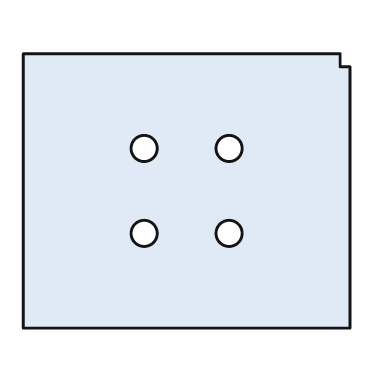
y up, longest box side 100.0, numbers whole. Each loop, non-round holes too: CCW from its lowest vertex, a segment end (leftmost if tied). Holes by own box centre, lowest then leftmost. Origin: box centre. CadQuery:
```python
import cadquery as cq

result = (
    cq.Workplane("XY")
    .moveTo(-50.0, -42.0)
    .lineTo(50.0, -42.0)
    .lineTo(50.0, 38.0)
    .lineTo(47.0, 38.0)
    .lineTo(47.0, 42.0)
    .lineTo(-50.0, 42.0)
    .close()
    .moveTo(-13.0, -13.0)
    .circle(4.0)
    .moveTo(13.0, -13.0)
    .circle(4.0)
    .moveTo(-13.0, 13.0)
    .circle(4.0)
    .moveTo(13.0, 13.0)
    .circle(4.0)
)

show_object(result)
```